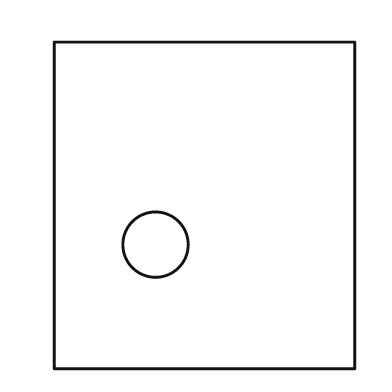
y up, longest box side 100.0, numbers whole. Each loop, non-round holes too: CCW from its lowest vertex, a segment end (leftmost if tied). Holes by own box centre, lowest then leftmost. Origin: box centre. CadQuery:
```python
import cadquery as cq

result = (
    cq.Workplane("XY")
    .moveTo(-46.0, -50.0)
    .lineTo(46.0, -50.0)
    .lineTo(46.0, 50.0)
    .lineTo(-46.0, 50.0)
    .close()
    .moveTo(-15.0, -12.0)
    .circle(10.0)
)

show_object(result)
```